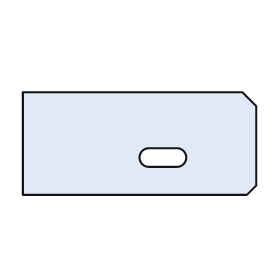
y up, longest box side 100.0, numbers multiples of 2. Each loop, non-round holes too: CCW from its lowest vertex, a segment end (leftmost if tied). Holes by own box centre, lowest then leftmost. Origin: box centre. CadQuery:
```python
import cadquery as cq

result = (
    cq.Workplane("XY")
    .moveTo(-50.0, -22.0)
    .lineTo(46.0, -22.0)
    .lineTo(50.0, -18.0)
    .lineTo(50.0, 16.0)
    .lineTo(44.0, 22.0)
    .lineTo(-50.0, 22.0)
    .close()
    .moveTo(4.0, -10.0)
    .lineTo(16.0, -10.0)
    .threePointArc((20.0, -6.0), (16.0, -2.0))
    .lineTo(4.0, -2.0)
    .threePointArc((0.0, -6.0), (4.0, -10.0))
    .close()
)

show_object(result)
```